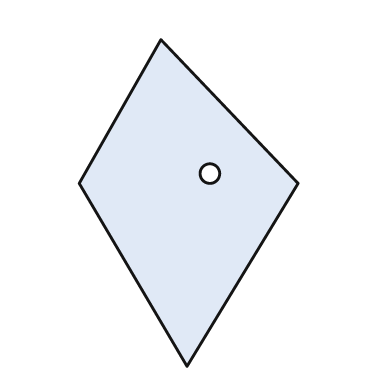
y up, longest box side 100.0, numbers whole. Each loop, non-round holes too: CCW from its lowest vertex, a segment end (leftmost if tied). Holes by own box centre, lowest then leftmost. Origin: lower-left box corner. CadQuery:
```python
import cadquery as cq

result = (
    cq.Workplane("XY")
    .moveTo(33.0, 0.0)
    .lineTo(67.0, 56.0)
    .lineTo(25.0, 100.0)
    .lineTo(0.0, 56.0)
    .close()
    .moveTo(40.0, 59.0)
    .circle(3.0)
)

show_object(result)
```